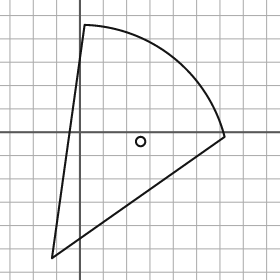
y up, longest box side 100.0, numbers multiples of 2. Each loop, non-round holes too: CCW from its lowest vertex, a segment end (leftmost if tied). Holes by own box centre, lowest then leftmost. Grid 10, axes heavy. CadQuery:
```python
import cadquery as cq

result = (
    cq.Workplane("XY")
    .moveTo(-12.0, -54.0)
    .lineTo(62.0, -2.0)
    .threePointArc((40.0, 32.0), (2.0, 46.0))
    .close()
    .moveTo(26.0, -4.0)
    .circle(2.0)
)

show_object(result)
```